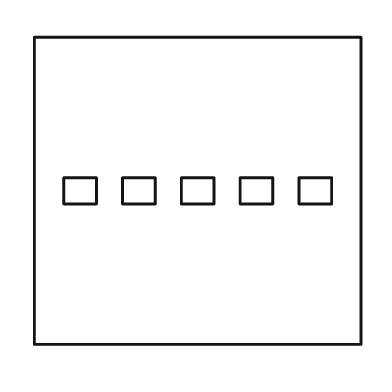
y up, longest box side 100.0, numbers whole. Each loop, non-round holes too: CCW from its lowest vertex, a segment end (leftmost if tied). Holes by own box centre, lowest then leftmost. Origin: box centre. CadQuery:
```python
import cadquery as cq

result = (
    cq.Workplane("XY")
    .moveTo(-50.0, -47.0)
    .lineTo(50.0, -47.0)
    .lineTo(50.0, 47.0)
    .lineTo(-50.0, 47.0)
    .close()
    .moveTo(-41.0, -4.0)
    .lineTo(-31.0, -4.0)
    .lineTo(-31.0, 4.0)
    .lineTo(-41.0, 4.0)
    .close()
    .moveTo(-23.0, -4.0)
    .lineTo(-13.0, -4.0)
    .lineTo(-13.0, 4.0)
    .lineTo(-23.0, 4.0)
    .close()
    .moveTo(-5.0, -4.0)
    .lineTo(5.0, -4.0)
    .lineTo(5.0, 4.0)
    .lineTo(-5.0, 4.0)
    .close()
    .moveTo(13.0, -4.0)
    .lineTo(23.0, -4.0)
    .lineTo(23.0, 4.0)
    .lineTo(13.0, 4.0)
    .close()
    .moveTo(31.0, -4.0)
    .lineTo(41.0, -4.0)
    .lineTo(41.0, 4.0)
    .lineTo(31.0, 4.0)
    .close()
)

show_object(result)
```